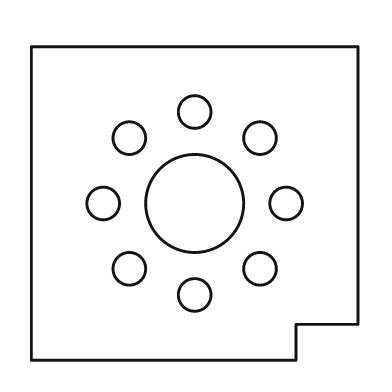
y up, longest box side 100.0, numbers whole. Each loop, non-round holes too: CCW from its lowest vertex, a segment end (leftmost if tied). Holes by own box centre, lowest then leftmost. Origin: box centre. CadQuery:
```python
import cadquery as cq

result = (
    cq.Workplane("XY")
    .moveTo(-50.0, -48.0)
    .lineTo(31.0, -48.0)
    .lineTo(31.0, -37.0)
    .lineTo(50.0, -37.0)
    .lineTo(50.0, 48.0)
    .lineTo(-50.0, 48.0)
    .close()
    .moveTo(0.0, -28.0)
    .circle(5.0)
    .moveTo(-20.0, -20.0)
    .circle(5.0)
    .moveTo(20.0, -20.0)
    .circle(5.0)
    .moveTo(-28.0, 0.0)
    .circle(5.0)
    .moveTo(0.0, 0.0)
    .circle(15.0)
    .moveTo(28.0, 0.0)
    .circle(5.0)
    .moveTo(-20.0, 20.0)
    .circle(5.0)
    .moveTo(20.0, 20.0)
    .circle(5.0)
    .moveTo(0.0, 28.0)
    .circle(5.0)
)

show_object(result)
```